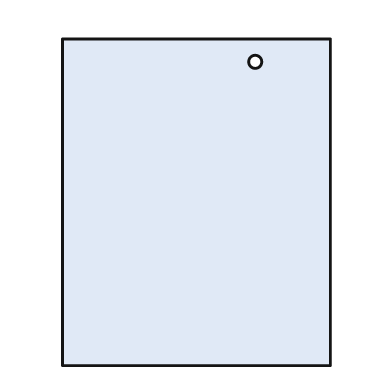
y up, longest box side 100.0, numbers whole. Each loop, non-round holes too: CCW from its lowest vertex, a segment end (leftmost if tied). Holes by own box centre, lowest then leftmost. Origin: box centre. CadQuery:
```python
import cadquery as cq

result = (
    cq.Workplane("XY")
    .moveTo(-41.0, -50.0)
    .lineTo(41.0, -50.0)
    .lineTo(41.0, 50.0)
    .lineTo(-41.0, 50.0)
    .close()
    .moveTo(18.0, 43.0)
    .circle(2.0)
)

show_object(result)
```